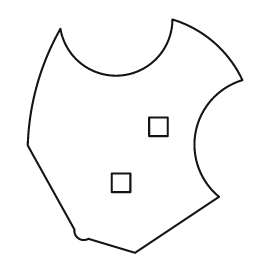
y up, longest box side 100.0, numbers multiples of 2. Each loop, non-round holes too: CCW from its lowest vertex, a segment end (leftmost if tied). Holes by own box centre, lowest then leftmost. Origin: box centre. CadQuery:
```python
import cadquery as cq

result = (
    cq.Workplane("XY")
    .moveTo(0.0, -50.0)
    .lineTo(36.0, -26.0)
    .threePointArc((26.0, 2.0), (46.0, 24.0))
    .threePointArc((34.0, 40.0), (16.0, 50.0))
    .threePointArc((-6.0, 26.0), (-32.0, 46.0))
    .threePointArc((-42.0, 22.0), (-46.0, -4.0))
    .lineTo(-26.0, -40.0)
    .threePointArc((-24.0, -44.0), (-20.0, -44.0))
    .close()
    .moveTo(-10.0, -24.0)
    .lineTo(-2.0, -24.0)
    .lineTo(-2.0, -16.0)
    .lineTo(-10.0, -16.0)
    .close()
    .moveTo(6.0, 0.0)
    .lineTo(14.0, 0.0)
    .lineTo(14.0, 8.0)
    .lineTo(6.0, 8.0)
    .close()
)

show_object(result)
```